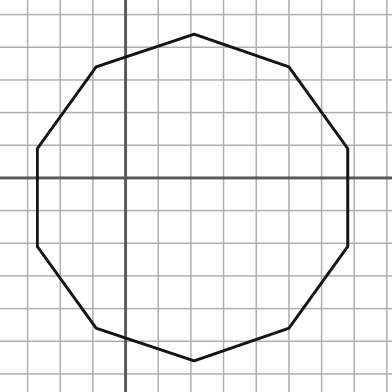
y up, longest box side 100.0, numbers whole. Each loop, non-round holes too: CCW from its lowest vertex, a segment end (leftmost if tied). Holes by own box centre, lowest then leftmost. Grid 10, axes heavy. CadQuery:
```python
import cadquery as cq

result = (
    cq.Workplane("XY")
    .moveTo(21.0, -56.0)
    .lineTo(50.0, -46.0)
    .lineTo(68.0, -21.0)
    .lineTo(68.0, 9.0)
    .lineTo(50.0, 34.0)
    .lineTo(21.0, 44.0)
    .lineTo(-9.0, 34.0)
    .lineTo(-27.0, 9.0)
    .lineTo(-27.0, -21.0)
    .lineTo(-9.0, -46.0)
    .close()
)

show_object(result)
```